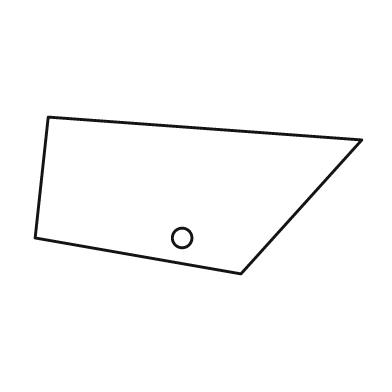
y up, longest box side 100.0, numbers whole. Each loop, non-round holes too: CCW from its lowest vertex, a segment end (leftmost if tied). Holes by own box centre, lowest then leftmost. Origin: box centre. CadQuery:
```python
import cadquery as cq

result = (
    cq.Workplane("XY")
    .moveTo(13.0, -24.0)
    .lineTo(50.0, 17.0)
    .lineTo(-46.0, 24.0)
    .lineTo(-50.0, -13.0)
    .close()
    .moveTo(-5.0, -13.0)
    .circle(3.0)
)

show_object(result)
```